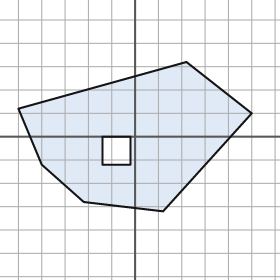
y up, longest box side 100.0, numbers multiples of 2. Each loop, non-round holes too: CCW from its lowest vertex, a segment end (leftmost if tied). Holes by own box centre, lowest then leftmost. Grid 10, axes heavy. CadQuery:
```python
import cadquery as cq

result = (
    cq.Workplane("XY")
    .moveTo(12.0, -32.0)
    .lineTo(50.0, 10.0)
    .lineTo(22.0, 32.0)
    .lineTo(-50.0, 12.0)
    .lineTo(-40.0, -12.0)
    .lineTo(-22.0, -28.0)
    .close()
    .moveTo(-14.0, -12.0)
    .lineTo(-2.0, -12.0)
    .lineTo(-2.0, 0.0)
    .lineTo(-14.0, 0.0)
    .close()
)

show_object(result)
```